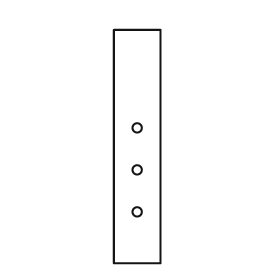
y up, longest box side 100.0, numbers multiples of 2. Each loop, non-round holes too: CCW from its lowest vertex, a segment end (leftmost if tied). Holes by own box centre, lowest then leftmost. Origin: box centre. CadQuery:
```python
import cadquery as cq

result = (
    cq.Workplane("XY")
    .moveTo(-10.0, -50.0)
    .lineTo(10.0, -50.0)
    .lineTo(10.0, 50.0)
    .lineTo(-10.0, 50.0)
    .close()
    .moveTo(0.0, -28.0)
    .circle(2.0)
    .moveTo(0.0, -10.0)
    .circle(2.0)
    .moveTo(0.0, 8.0)
    .circle(2.0)
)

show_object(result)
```